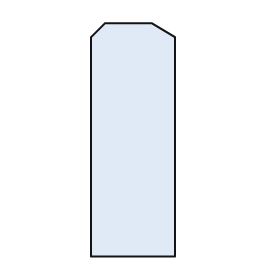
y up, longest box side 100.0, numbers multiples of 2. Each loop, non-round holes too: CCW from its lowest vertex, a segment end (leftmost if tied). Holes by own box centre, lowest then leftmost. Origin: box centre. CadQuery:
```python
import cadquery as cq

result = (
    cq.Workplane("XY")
    .moveTo(-18.0, -50.0)
    .lineTo(18.0, -50.0)
    .lineTo(18.0, 44.0)
    .lineTo(8.0, 50.0)
    .lineTo(-12.0, 50.0)
    .lineTo(-18.0, 44.0)
    .close()
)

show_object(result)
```